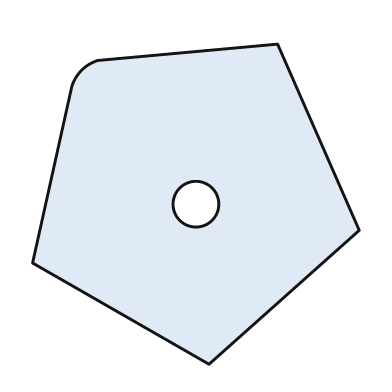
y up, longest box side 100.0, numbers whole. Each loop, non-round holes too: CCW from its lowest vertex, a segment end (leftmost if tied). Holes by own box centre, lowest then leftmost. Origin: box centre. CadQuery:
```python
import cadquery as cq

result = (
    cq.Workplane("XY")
    .moveTo(4.0, -49.0)
    .lineTo(50.0, -8.0)
    .lineTo(25.0, 49.0)
    .lineTo(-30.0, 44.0)
    .threePointArc((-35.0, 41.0), (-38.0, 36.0))
    .lineTo(-50.0, -18.0)
    .close()
    .moveTo(0.0, 0.0)
    .circle(7.0)
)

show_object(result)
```